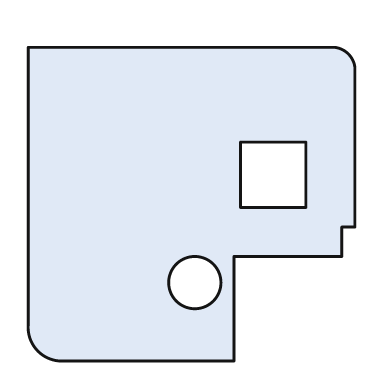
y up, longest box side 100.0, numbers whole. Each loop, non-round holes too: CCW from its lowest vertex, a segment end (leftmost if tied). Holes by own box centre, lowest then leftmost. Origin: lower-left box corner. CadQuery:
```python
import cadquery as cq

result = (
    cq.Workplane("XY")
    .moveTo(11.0, 0.0)
    .lineTo(63.0, 0.0)
    .lineTo(63.0, 32.0)
    .lineTo(96.0, 32.0)
    .lineTo(96.0, 41.0)
    .lineTo(100.0, 41.0)
    .lineTo(100.0, 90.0)
    .threePointArc((98.0, 94.0), (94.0, 96.0))
    .lineTo(0.0, 96.0)
    .lineTo(0.0, 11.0)
    .threePointArc((3.0, 3.0), (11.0, 0.0))
    .close()
    .moveTo(51.0, 24.0)
    .circle(8.0)
    .moveTo(65.0, 47.0)
    .lineTo(85.0, 47.0)
    .lineTo(85.0, 67.0)
    .lineTo(65.0, 67.0)
    .close()
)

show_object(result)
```